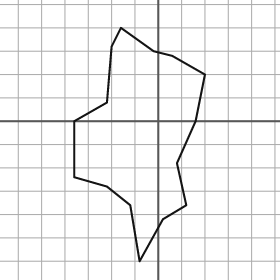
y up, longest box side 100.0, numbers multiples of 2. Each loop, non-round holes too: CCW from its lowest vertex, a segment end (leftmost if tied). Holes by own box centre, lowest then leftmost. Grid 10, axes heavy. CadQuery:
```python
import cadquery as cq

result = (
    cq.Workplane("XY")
    .moveTo(-8.0, -60.0)
    .lineTo(2.0, -42.0)
    .lineTo(12.0, -36.0)
    .lineTo(8.0, -18.0)
    .lineTo(16.0, 0.0)
    .lineTo(20.0, 20.0)
    .lineTo(6.0, 28.0)
    .lineTo(-2.0, 30.0)
    .lineTo(-16.0, 40.0)
    .lineTo(-20.0, 32.0)
    .lineTo(-22.0, 8.0)
    .lineTo(-36.0, 0.0)
    .lineTo(-36.0, -24.0)
    .lineTo(-22.0, -28.0)
    .lineTo(-12.0, -36.0)
    .close()
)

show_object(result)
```